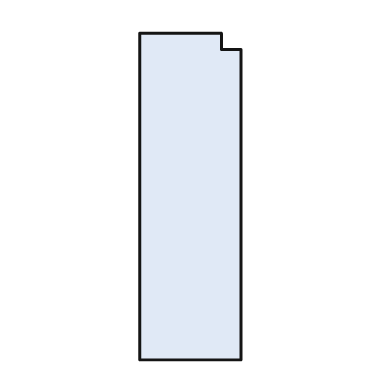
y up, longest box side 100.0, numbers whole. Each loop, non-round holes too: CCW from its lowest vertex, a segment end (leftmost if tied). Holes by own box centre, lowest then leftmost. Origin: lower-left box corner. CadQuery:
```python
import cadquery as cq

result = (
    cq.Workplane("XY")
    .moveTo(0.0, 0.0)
    .lineTo(31.0, 0.0)
    .lineTo(31.0, 95.0)
    .lineTo(25.0, 95.0)
    .lineTo(25.0, 100.0)
    .lineTo(0.0, 100.0)
    .close()
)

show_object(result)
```